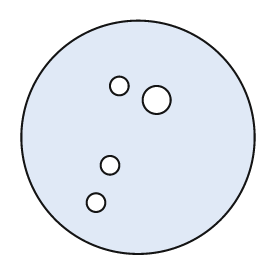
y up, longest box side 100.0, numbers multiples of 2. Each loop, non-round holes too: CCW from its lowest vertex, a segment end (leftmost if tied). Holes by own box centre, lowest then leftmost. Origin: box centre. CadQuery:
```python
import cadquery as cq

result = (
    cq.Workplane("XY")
    .moveTo(0.0, 0.0)
    .circle(50.0)
    .moveTo(-18.0, -28.0)
    .circle(4.0)
    .moveTo(-12.0, -12.0)
    .circle(4.0)
    .moveTo(8.0, 16.0)
    .circle(6.0)
    .moveTo(-8.0, 22.0)
    .circle(4.0)
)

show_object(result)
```